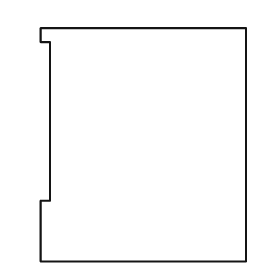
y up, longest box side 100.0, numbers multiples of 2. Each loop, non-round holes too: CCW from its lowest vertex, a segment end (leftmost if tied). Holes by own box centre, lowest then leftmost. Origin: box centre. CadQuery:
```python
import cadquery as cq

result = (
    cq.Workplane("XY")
    .moveTo(-44.0, -50.0)
    .lineTo(44.0, -50.0)
    .lineTo(44.0, 50.0)
    .lineTo(-44.0, 50.0)
    .lineTo(-44.0, 44.0)
    .lineTo(-40.0, 44.0)
    .lineTo(-40.0, -24.0)
    .lineTo(-44.0, -24.0)
    .close()
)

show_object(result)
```